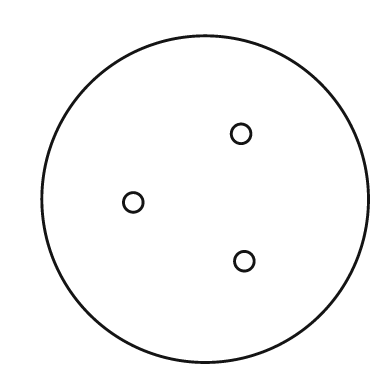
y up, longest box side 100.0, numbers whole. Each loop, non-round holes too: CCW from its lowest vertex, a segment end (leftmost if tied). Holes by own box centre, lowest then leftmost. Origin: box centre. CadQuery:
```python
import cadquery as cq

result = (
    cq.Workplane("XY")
    .moveTo(0.0, 0.0)
    .circle(50.0)
    .moveTo(12.0, -19.0)
    .circle(3.0)
    .moveTo(-22.0, -1.0)
    .circle(3.0)
    .moveTo(11.0, 20.0)
    .circle(3.0)
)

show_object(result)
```